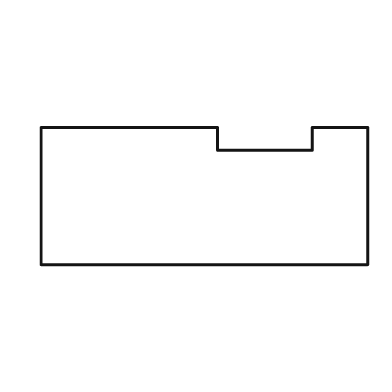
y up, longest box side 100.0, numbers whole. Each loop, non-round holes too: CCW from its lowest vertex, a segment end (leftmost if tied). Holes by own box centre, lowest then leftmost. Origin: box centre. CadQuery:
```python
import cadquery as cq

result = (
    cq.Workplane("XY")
    .moveTo(-50.0, -21.0)
    .lineTo(50.0, -21.0)
    .lineTo(50.0, 21.0)
    .lineTo(33.0, 21.0)
    .lineTo(33.0, 14.0)
    .lineTo(4.0, 14.0)
    .lineTo(4.0, 21.0)
    .lineTo(-50.0, 21.0)
    .close()
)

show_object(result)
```